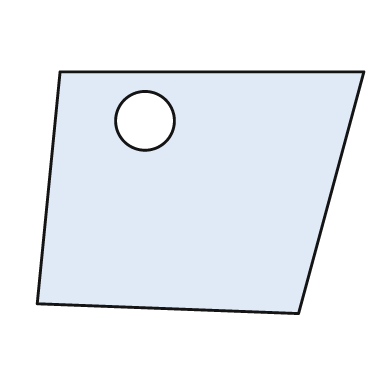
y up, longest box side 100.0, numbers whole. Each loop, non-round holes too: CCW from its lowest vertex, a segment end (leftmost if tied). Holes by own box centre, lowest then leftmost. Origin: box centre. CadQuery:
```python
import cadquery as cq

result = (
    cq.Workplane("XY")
    .moveTo(30.0, -37.0)
    .lineTo(50.0, 37.0)
    .lineTo(-43.0, 37.0)
    .lineTo(-50.0, -34.0)
    .close()
    .moveTo(-17.0, 22.0)
    .circle(9.0)
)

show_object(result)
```